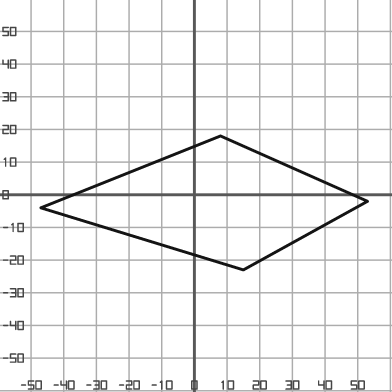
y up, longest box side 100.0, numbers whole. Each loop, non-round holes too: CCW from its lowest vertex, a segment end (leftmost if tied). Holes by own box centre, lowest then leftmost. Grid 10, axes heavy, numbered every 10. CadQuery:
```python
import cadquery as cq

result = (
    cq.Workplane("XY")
    .moveTo(15.0, -23.0)
    .lineTo(53.0, -2.0)
    .lineTo(8.0, 18.0)
    .lineTo(-47.0, -4.0)
    .close()
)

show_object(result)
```